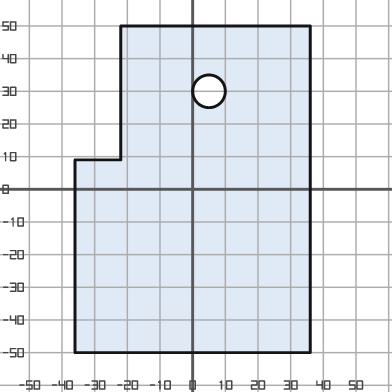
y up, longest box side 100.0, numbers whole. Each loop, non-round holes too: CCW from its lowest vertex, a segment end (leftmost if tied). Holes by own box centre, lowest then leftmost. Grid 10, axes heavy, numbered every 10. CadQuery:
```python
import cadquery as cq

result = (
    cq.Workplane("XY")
    .moveTo(-36.0, -50.0)
    .lineTo(36.0, -50.0)
    .lineTo(36.0, 50.0)
    .lineTo(-22.0, 50.0)
    .lineTo(-22.0, 9.0)
    .lineTo(-36.0, 9.0)
    .close()
    .moveTo(5.0, 30.0)
    .circle(5.0)
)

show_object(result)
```